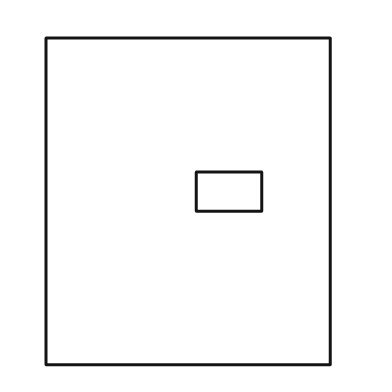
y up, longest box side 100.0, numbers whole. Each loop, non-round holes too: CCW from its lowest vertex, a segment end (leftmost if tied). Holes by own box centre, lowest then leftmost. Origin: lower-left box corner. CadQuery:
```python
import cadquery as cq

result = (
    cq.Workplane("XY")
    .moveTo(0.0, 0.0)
    .lineTo(87.0, 0.0)
    .lineTo(87.0, 100.0)
    .lineTo(0.0, 100.0)
    .close()
    .moveTo(46.0, 47.0)
    .lineTo(66.0, 47.0)
    .lineTo(66.0, 59.0)
    .lineTo(46.0, 59.0)
    .close()
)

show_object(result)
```